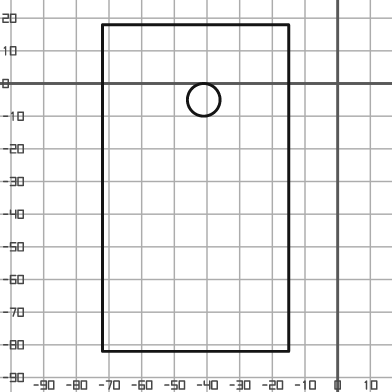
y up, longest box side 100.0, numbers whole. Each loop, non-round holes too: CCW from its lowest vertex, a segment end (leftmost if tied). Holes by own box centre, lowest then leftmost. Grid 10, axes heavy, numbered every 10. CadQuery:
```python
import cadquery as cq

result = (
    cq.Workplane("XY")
    .moveTo(-72.0, -82.0)
    .lineTo(-15.0, -82.0)
    .lineTo(-15.0, 18.0)
    .lineTo(-72.0, 18.0)
    .close()
    .moveTo(-41.0, -5.0)
    .circle(5.0)
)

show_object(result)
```